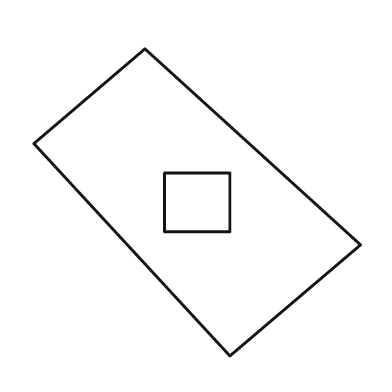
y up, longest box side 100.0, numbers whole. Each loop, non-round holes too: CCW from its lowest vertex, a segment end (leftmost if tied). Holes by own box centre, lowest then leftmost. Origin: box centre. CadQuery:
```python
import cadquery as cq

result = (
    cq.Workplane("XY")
    .moveTo(10.0, -47.0)
    .lineTo(50.0, -13.0)
    .lineTo(-16.0, 47.0)
    .lineTo(-50.0, 18.0)
    .close()
    .moveTo(-10.0, -9.0)
    .lineTo(10.0, -9.0)
    .lineTo(10.0, 9.0)
    .lineTo(-10.0, 9.0)
    .close()
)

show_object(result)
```